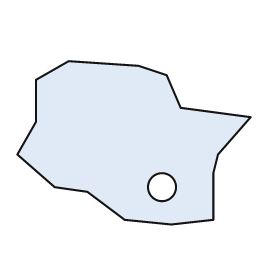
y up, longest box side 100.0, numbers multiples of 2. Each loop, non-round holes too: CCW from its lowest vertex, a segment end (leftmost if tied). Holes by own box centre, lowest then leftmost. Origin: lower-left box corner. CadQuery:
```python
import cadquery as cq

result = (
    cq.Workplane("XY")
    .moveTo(66.0, 0.0)
    .lineTo(84.0, 2.0)
    .lineTo(84.0, 22.0)
    .lineTo(86.0, 30.0)
    .lineTo(100.0, 46.0)
    .lineTo(70.0, 50.0)
    .lineTo(64.0, 64.0)
    .lineTo(52.0, 68.0)
    .lineTo(22.0, 70.0)
    .lineTo(8.0, 62.0)
    .lineTo(8.0, 44.0)
    .lineTo(0.0, 30.0)
    .lineTo(16.0, 16.0)
    .lineTo(30.0, 14.0)
    .lineTo(46.0, 2.0)
    .close()
    .moveTo(62.0, 16.0)
    .circle(6.0)
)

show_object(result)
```